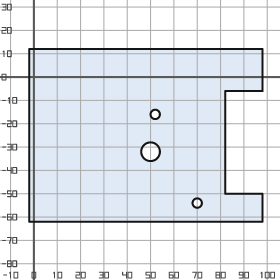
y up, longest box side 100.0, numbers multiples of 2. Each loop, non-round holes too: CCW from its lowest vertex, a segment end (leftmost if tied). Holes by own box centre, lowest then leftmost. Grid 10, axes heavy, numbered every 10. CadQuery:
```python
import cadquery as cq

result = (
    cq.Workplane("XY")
    .moveTo(-2.0, -62.0)
    .lineTo(98.0, -62.0)
    .lineTo(98.0, -50.0)
    .lineTo(82.0, -50.0)
    .lineTo(82.0, -6.0)
    .lineTo(98.0, -6.0)
    .lineTo(98.0, 12.0)
    .lineTo(-2.0, 12.0)
    .close()
    .moveTo(70.0, -54.0)
    .circle(2.0)
    .moveTo(50.0, -32.0)
    .circle(4.0)
    .moveTo(52.0, -16.0)
    .circle(2.0)
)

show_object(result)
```